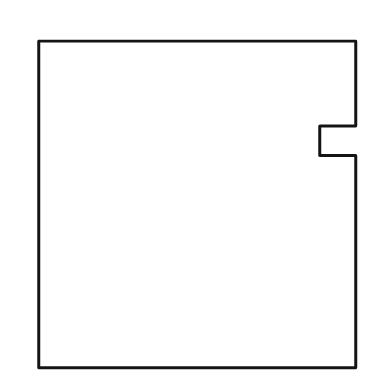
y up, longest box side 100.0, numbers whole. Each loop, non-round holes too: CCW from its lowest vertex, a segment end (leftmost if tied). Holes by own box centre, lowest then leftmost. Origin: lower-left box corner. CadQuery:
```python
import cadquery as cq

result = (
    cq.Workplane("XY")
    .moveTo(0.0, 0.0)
    .lineTo(97.0, 0.0)
    .lineTo(97.0, 65.0)
    .lineTo(86.0, 65.0)
    .lineTo(86.0, 74.0)
    .lineTo(97.0, 74.0)
    .lineTo(97.0, 100.0)
    .lineTo(0.0, 100.0)
    .close()
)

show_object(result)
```